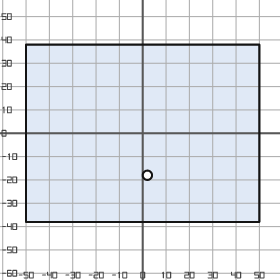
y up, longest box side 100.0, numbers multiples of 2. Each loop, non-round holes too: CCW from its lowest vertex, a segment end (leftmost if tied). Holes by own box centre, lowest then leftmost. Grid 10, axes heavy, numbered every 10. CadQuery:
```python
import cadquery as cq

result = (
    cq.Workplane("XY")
    .moveTo(-50.0, -38.0)
    .lineTo(50.0, -38.0)
    .lineTo(50.0, 38.0)
    .lineTo(-50.0, 38.0)
    .close()
    .moveTo(2.0, -18.0)
    .circle(2.0)
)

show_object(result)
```